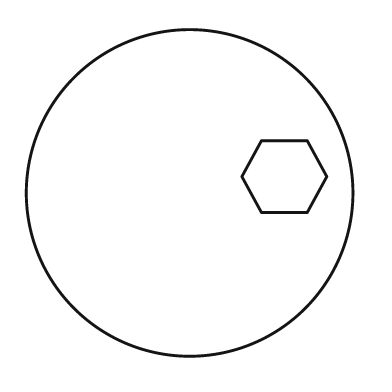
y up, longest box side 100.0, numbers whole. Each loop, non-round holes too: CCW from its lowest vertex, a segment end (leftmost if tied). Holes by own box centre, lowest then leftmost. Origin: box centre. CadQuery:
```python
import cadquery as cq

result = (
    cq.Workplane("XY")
    .moveTo(0.0, 0.0)
    .circle(50.0)
    .moveTo(22.0, -6.0)
    .lineTo(36.0, -6.0)
    .lineTo(42.0, 5.0)
    .lineTo(36.0, 16.0)
    .lineTo(22.0, 16.0)
    .lineTo(16.0, 5.0)
    .close()
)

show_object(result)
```